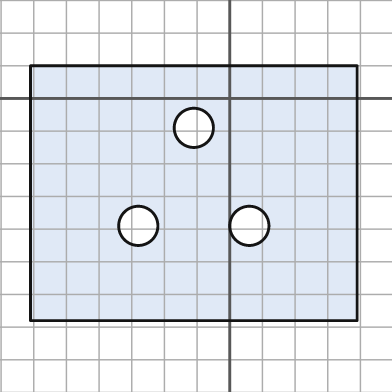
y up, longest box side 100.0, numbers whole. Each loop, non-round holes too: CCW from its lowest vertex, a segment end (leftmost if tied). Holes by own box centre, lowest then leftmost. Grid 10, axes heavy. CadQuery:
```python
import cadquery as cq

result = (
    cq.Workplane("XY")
    .moveTo(-61.0, -68.0)
    .lineTo(39.0, -68.0)
    .lineTo(39.0, 10.0)
    .lineTo(-61.0, 10.0)
    .close()
    .moveTo(-28.0, -39.0)
    .circle(6.0)
    .moveTo(6.0, -39.0)
    .circle(6.0)
    .moveTo(-11.0, -9.0)
    .circle(6.0)
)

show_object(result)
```